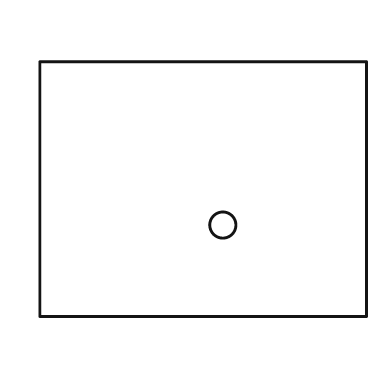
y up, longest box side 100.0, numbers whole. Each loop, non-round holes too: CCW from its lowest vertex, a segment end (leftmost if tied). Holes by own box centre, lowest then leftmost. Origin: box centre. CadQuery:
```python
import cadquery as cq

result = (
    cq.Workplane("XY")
    .moveTo(-50.0, -39.0)
    .lineTo(50.0, -39.0)
    .lineTo(50.0, 39.0)
    .lineTo(-50.0, 39.0)
    .close()
    .moveTo(6.0, -11.0)
    .circle(4.0)
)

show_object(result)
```